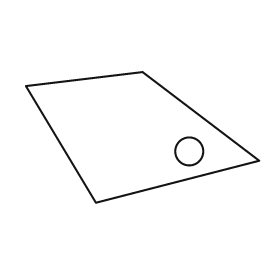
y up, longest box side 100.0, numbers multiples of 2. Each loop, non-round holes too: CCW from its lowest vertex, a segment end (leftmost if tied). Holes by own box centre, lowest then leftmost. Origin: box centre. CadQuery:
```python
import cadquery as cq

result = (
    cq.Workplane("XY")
    .moveTo(-20.0, -28.0)
    .lineTo(50.0, -10.0)
    .lineTo(0.0, 28.0)
    .lineTo(-50.0, 22.0)
    .close()
    .moveTo(20.0, -6.0)
    .circle(6.0)
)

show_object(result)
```